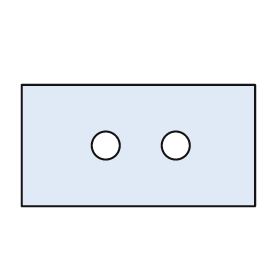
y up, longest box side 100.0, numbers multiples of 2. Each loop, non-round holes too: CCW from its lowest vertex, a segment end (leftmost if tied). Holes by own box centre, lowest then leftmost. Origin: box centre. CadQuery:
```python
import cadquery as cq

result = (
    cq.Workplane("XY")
    .moveTo(-50.0, -26.0)
    .lineTo(50.0, -26.0)
    .lineTo(50.0, 26.0)
    .lineTo(-50.0, 26.0)
    .close()
    .moveTo(-14.0, 0.0)
    .circle(6.0)
    .moveTo(16.0, 0.0)
    .circle(6.0)
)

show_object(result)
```